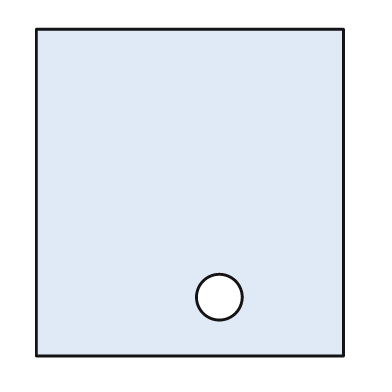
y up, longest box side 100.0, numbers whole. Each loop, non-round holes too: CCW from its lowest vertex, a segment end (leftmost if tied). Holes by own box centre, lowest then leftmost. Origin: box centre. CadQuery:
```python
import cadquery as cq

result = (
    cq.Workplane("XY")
    .moveTo(-47.0, -50.0)
    .lineTo(47.0, -50.0)
    .lineTo(47.0, 50.0)
    .lineTo(-47.0, 50.0)
    .close()
    .moveTo(9.0, -32.0)
    .circle(7.0)
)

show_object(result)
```